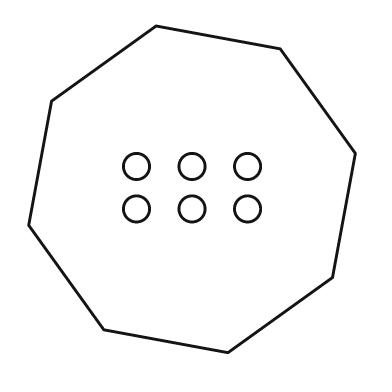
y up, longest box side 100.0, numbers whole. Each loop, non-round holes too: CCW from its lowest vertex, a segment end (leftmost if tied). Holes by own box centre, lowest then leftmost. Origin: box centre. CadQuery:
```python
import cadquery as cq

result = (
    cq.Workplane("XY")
    .moveTo(11.0, -50.0)
    .lineTo(43.0, -27.0)
    .lineTo(50.0, 11.0)
    .lineTo(27.0, 43.0)
    .lineTo(-11.0, 50.0)
    .lineTo(-43.0, 27.0)
    .lineTo(-50.0, -11.0)
    .lineTo(-27.0, -43.0)
    .close()
    .moveTo(-17.0, -6.0)
    .circle(4.0)
    .moveTo(0.0, -6.0)
    .circle(4.0)
    .moveTo(17.0, -6.0)
    .circle(4.0)
    .moveTo(-17.0, 7.0)
    .circle(4.0)
    .moveTo(0.0, 7.0)
    .circle(4.0)
    .moveTo(17.0, 7.0)
    .circle(4.0)
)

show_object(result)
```